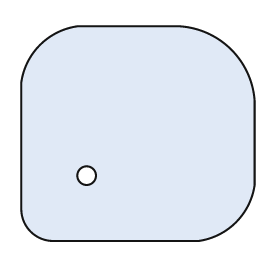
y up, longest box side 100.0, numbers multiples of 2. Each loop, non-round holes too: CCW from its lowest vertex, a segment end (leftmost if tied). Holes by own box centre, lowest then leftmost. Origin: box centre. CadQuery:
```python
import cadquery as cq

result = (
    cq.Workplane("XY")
    .moveTo(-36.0, -46.0)
    .lineTo(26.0, -46.0)
    .threePointArc((42.0, -38.0), (50.0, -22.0))
    .lineTo(50.0, 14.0)
    .threePointArc((40.0, 36.0), (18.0, 46.0))
    .lineTo(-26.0, 46.0)
    .threePointArc((-42.0, 38.0), (-50.0, 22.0))
    .lineTo(-50.0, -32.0)
    .threePointArc((-46.0, -42.0), (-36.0, -46.0))
    .close()
    .moveTo(-22.0, -18.0)
    .circle(4.0)
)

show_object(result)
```